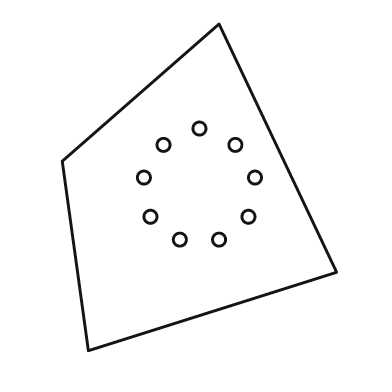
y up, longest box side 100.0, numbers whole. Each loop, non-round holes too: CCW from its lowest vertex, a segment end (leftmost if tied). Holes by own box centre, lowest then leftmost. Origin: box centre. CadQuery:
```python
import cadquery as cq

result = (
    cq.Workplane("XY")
    .moveTo(-34.0, -50.0)
    .lineTo(42.0, -26.0)
    .lineTo(6.0, 50.0)
    .lineTo(-42.0, 8.0)
    .close()
    .moveTo(-6.0, -16.0)
    .circle(2.0)
    .moveTo(6.0, -16.0)
    .circle(2.0)
    .moveTo(-15.0, -9.0)
    .circle(2.0)
    .moveTo(15.0, -9.0)
    .circle(2.0)
    .moveTo(-17.0, 3.0)
    .circle(2.0)
    .moveTo(17.0, 3.0)
    .circle(2.0)
    .moveTo(-11.0, 13.0)
    .circle(2.0)
    .moveTo(11.0, 13.0)
    .circle(2.0)
    .moveTo(0.0, 18.0)
    .circle(2.0)
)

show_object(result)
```